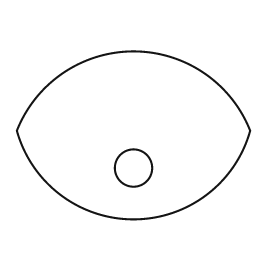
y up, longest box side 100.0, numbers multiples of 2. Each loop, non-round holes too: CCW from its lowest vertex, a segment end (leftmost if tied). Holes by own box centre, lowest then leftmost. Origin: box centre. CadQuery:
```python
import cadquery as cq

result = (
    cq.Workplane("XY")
    .moveTo(-50.0, 2.0)
    .threePointArc((0.0, -36.0), (50.0, 2.0))
    .threePointArc((0.0, 36.0), (-50.0, 2.0))
    .close()
    .moveTo(0.0, -14.0)
    .circle(8.0)
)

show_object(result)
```